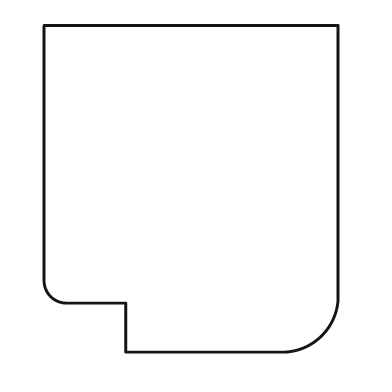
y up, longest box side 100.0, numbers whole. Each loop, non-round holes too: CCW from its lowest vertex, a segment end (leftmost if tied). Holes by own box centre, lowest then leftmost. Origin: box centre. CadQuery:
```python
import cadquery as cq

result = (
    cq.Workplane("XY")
    .moveTo(-20.0, -50.0)
    .lineTo(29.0, -50.0)
    .threePointArc((40.0, -45.0), (45.0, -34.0))
    .lineTo(45.0, 50.0)
    .lineTo(-45.0, 50.0)
    .lineTo(-45.0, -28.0)
    .threePointArc((-43.0, -33.0), (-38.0, -35.0))
    .lineTo(-20.0, -35.0)
    .close()
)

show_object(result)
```